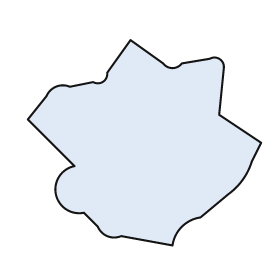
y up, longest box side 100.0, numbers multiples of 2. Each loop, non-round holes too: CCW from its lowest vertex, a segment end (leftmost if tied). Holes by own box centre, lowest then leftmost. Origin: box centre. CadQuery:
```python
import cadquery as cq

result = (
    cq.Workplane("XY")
    .moveTo(12.0, -44.0)
    .threePointArc((16.0, -36.0), (24.0, -32.0))
    .lineTo(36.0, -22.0)
    .threePointArc((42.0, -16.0), (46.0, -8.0))
    .lineTo(50.0, 0.0)
    .lineTo(32.0, 12.0)
    .lineTo(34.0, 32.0)
    .threePointArc((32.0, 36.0), (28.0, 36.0))
    .lineTo(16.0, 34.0)
    .threePointArc((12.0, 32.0), (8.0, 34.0))
    .lineTo(-6.0, 44.0)
    .lineTo(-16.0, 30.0)
    .threePointArc((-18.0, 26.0), (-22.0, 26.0))
    .lineTo(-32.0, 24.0)
    .threePointArc((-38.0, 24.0), (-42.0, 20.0))
    .lineTo(-50.0, 10.0)
    .lineTo(-30.0, -10.0)
    .threePointArc((-38.0, -22.0), (-26.0, -30.0))
    .lineTo(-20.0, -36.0)
    .threePointArc((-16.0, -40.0), (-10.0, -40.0))
    .close()
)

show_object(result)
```